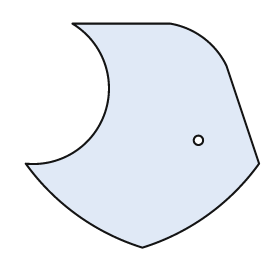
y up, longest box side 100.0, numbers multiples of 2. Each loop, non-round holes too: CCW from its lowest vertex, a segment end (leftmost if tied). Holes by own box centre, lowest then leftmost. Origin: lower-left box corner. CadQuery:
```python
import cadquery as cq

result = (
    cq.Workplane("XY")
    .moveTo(50.0, 0.0)
    .threePointArc((78.0, 14.0), (100.0, 36.0))
    .lineTo(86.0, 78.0)
    .threePointArc((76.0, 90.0), (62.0, 96.0))
    .lineTo(20.0, 96.0)
    .threePointArc((34.0, 58.0), (0.0, 36.0))
    .threePointArc((22.0, 14.0), (50.0, 0.0))
    .close()
    .moveTo(74.0, 46.0)
    .circle(2.0)
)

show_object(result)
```